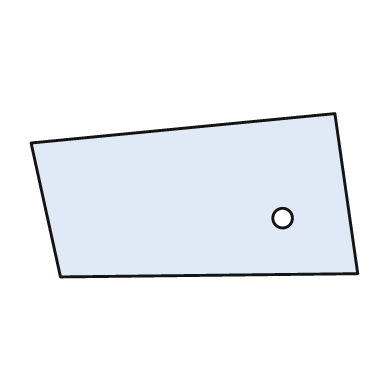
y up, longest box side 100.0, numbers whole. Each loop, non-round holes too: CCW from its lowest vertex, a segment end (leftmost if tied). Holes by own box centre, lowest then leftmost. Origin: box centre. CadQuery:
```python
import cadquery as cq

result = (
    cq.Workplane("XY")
    .moveTo(-41.0, -25.0)
    .lineTo(50.0, -24.0)
    .lineTo(43.0, 25.0)
    .lineTo(-50.0, 16.0)
    .close()
    .moveTo(27.0, -7.0)
    .circle(3.0)
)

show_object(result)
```